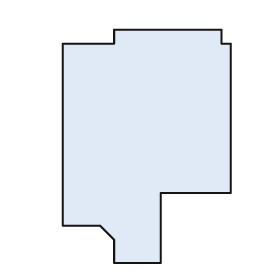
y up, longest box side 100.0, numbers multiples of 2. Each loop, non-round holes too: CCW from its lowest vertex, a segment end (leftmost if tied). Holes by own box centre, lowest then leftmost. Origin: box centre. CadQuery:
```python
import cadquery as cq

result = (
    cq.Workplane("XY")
    .moveTo(-14.0, -50.0)
    .lineTo(6.0, -50.0)
    .lineTo(6.0, -20.0)
    .lineTo(36.0, -20.0)
    .lineTo(36.0, 44.0)
    .lineTo(32.0, 44.0)
    .lineTo(32.0, 50.0)
    .lineTo(-14.0, 50.0)
    .lineTo(-14.0, 44.0)
    .lineTo(-36.0, 44.0)
    .lineTo(-36.0, -34.0)
    .lineTo(-20.0, -34.0)
    .lineTo(-14.0, -40.0)
    .close()
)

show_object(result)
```